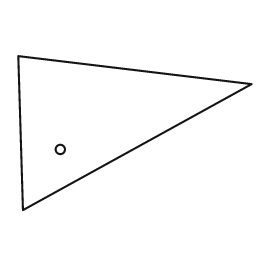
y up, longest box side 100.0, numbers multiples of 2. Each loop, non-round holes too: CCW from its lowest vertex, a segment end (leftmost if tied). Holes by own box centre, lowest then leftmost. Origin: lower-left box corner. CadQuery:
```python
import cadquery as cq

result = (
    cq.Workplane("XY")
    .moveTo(2.0, 0.0)
    .lineTo(100.0, 54.0)
    .lineTo(0.0, 66.0)
    .close()
    .moveTo(18.0, 26.0)
    .circle(2.0)
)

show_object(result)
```